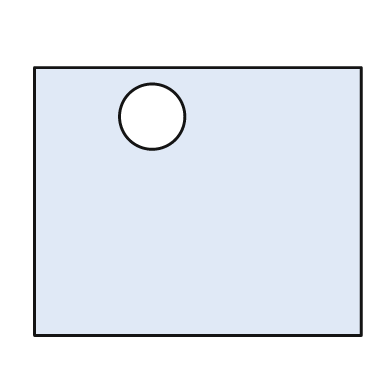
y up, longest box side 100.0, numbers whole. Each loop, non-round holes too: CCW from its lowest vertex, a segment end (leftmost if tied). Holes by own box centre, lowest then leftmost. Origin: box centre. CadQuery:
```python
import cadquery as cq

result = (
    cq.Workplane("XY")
    .moveTo(-50.0, -41.0)
    .lineTo(50.0, -41.0)
    .lineTo(50.0, 41.0)
    .lineTo(-50.0, 41.0)
    .close()
    .moveTo(-14.0, 26.0)
    .circle(10.0)
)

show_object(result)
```